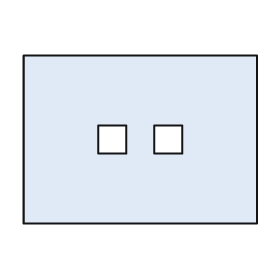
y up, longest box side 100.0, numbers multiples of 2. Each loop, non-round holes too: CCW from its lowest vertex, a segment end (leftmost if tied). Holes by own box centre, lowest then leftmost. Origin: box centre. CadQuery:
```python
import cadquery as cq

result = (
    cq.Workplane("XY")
    .moveTo(-50.0, -36.0)
    .lineTo(50.0, -36.0)
    .lineTo(50.0, 36.0)
    .lineTo(-50.0, 36.0)
    .close()
    .moveTo(-18.0, -6.0)
    .lineTo(-6.0, -6.0)
    .lineTo(-6.0, 6.0)
    .lineTo(-18.0, 6.0)
    .close()
    .moveTo(6.0, -6.0)
    .lineTo(18.0, -6.0)
    .lineTo(18.0, 6.0)
    .lineTo(6.0, 6.0)
    .close()
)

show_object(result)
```